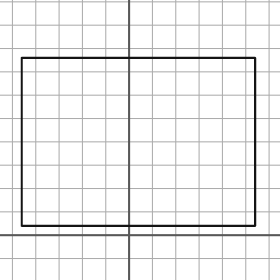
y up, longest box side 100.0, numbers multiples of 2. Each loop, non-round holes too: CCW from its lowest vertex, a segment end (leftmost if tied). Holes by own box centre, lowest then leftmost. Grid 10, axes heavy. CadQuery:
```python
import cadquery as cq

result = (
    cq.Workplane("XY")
    .moveTo(-46.0, 4.0)
    .lineTo(54.0, 4.0)
    .lineTo(54.0, 76.0)
    .lineTo(-46.0, 76.0)
    .close()
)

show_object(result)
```